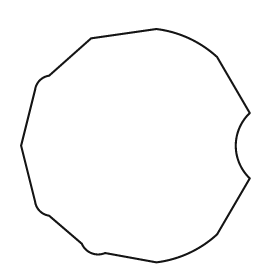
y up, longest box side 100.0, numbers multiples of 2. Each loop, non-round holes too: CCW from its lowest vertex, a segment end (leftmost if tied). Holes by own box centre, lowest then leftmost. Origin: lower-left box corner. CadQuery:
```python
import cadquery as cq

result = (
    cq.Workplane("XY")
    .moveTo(58.0, 0.0)
    .threePointArc((72.0, 4.0), (84.0, 12.0))
    .lineTo(98.0, 36.0)
    .threePointArc((92.0, 50.0), (98.0, 64.0))
    .lineTo(84.0, 88.0)
    .threePointArc((72.0, 96.0), (58.0, 100.0))
    .lineTo(30.0, 96.0)
    .lineTo(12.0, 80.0)
    .threePointArc((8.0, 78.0), (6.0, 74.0))
    .lineTo(0.0, 50.0)
    .lineTo(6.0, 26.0)
    .threePointArc((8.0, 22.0), (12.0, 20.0))
    .lineTo(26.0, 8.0)
    .threePointArc((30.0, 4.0), (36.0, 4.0))
    .close()
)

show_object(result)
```